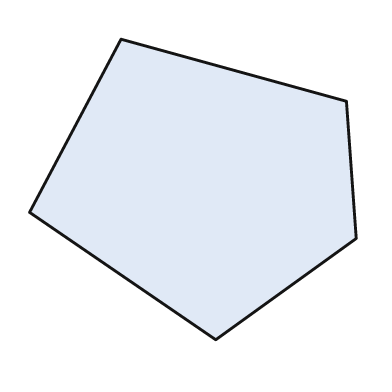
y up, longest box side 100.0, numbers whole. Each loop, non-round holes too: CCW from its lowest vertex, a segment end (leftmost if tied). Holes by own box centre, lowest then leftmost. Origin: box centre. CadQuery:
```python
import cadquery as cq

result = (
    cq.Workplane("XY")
    .moveTo(7.0, -46.0)
    .lineTo(50.0, -15.0)
    .lineTo(47.0, 27.0)
    .lineTo(-22.0, 46.0)
    .lineTo(-50.0, -7.0)
    .close()
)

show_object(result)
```